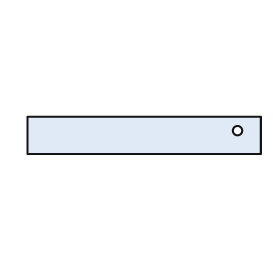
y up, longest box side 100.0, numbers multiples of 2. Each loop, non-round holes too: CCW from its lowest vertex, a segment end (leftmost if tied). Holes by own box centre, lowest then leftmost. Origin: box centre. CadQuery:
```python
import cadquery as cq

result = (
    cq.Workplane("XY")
    .moveTo(-50.0, -8.0)
    .lineTo(50.0, -8.0)
    .lineTo(50.0, 8.0)
    .lineTo(-50.0, 8.0)
    .close()
    .moveTo(40.0, 2.0)
    .circle(2.0)
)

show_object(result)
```